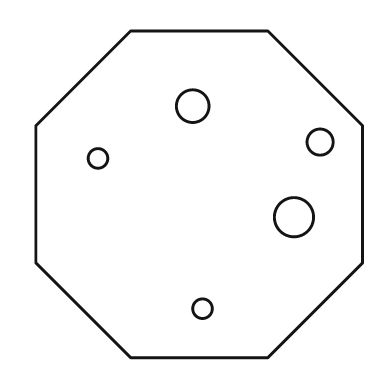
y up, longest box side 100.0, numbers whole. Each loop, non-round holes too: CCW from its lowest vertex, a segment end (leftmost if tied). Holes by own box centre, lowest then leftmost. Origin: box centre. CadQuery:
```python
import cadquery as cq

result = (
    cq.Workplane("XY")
    .moveTo(-21.0, -50.0)
    .lineTo(21.0, -50.0)
    .lineTo(50.0, -21.0)
    .lineTo(50.0, 21.0)
    .lineTo(21.0, 50.0)
    .lineTo(-21.0, 50.0)
    .lineTo(-50.0, 21.0)
    .lineTo(-50.0, -21.0)
    .close()
    .moveTo(1.0, -35.0)
    .circle(3.0)
    .moveTo(29.0, -7.0)
    .circle(6.0)
    .moveTo(-31.0, 11.0)
    .circle(3.0)
    .moveTo(37.0, 16.0)
    .circle(4.0)
    .moveTo(-2.0, 27.0)
    .circle(5.0)
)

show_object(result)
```